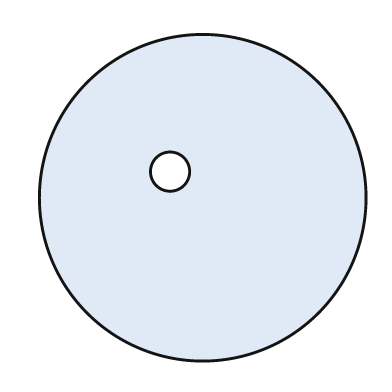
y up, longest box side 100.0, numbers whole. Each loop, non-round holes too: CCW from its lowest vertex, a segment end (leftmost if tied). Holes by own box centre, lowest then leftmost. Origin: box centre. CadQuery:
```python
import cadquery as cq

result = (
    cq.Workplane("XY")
    .moveTo(0.0, 0.0)
    .circle(50.0)
    .moveTo(-10.0, 8.0)
    .circle(6.0)
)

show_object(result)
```